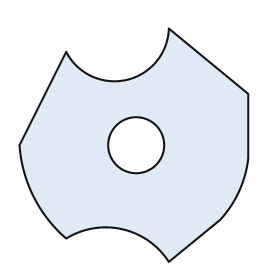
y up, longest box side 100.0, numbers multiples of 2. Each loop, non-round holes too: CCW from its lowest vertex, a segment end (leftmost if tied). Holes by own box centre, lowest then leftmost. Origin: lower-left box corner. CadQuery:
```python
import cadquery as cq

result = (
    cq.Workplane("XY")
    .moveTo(64.0, 0.0)
    .lineTo(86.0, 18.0)
    .threePointArc((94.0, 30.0), (98.0, 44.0))
    .lineTo(98.0, 72.0)
    .lineTo(64.0, 100.0)
    .threePointArc((46.0, 78.0), (20.0, 90.0))
    .lineTo(0.0, 50.0)
    .threePointArc((6.0, 28.0), (20.0, 10.0))
    .threePointArc((44.0, 14.0), (64.0, 0.0))
    .close()
    .moveTo(50.0, 50.0)
    .circle(12.0)
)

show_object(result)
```